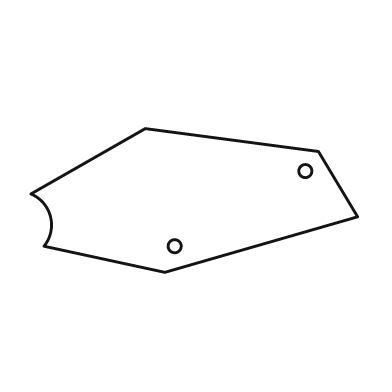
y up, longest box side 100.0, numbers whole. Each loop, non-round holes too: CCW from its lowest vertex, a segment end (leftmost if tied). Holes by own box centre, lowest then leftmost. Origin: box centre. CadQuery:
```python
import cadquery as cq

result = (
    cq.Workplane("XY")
    .moveTo(-9.0, -22.0)
    .lineTo(50.0, -5.0)
    .lineTo(38.0, 15.0)
    .lineTo(-15.0, 22.0)
    .lineTo(-50.0, 2.0)
    .threePointArc((-44.0, -5.0), (-46.0, -14.0))
    .close()
    .moveTo(-6.0, -14.0)
    .circle(2.0)
    .moveTo(34.0, 9.0)
    .circle(2.0)
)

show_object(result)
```